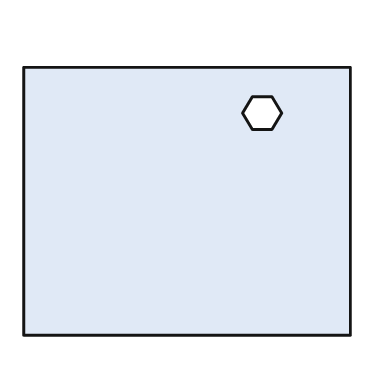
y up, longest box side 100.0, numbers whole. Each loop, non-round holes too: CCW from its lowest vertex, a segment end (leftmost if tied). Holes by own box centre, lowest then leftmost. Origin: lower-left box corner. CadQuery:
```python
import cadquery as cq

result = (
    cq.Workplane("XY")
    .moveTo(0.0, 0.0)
    .lineTo(100.0, 0.0)
    .lineTo(100.0, 82.0)
    .lineTo(0.0, 82.0)
    .close()
    .moveTo(70.0, 63.0)
    .lineTo(76.0, 63.0)
    .lineTo(79.0, 68.0)
    .lineTo(76.0, 73.0)
    .lineTo(70.0, 73.0)
    .lineTo(67.0, 68.0)
    .close()
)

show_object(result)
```